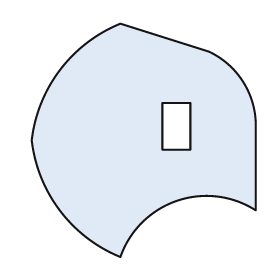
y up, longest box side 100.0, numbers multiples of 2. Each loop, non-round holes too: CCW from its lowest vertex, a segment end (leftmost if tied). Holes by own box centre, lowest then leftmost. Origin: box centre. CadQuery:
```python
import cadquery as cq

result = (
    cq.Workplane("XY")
    .moveTo(-10.0, -50.0)
    .threePointArc((14.0, -26.0), (48.0, -30.0))
    .lineTo(48.0, 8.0)
    .threePointArc((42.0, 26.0), (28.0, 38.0))
    .lineTo(-10.0, 50.0)
    .threePointArc((-36.0, 30.0), (-48.0, 0.0))
    .threePointArc((-36.0, -30.0), (-10.0, -50.0))
    .close()
    .moveTo(8.0, -4.0)
    .lineTo(20.0, -4.0)
    .lineTo(20.0, 16.0)
    .lineTo(8.0, 16.0)
    .close()
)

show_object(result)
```